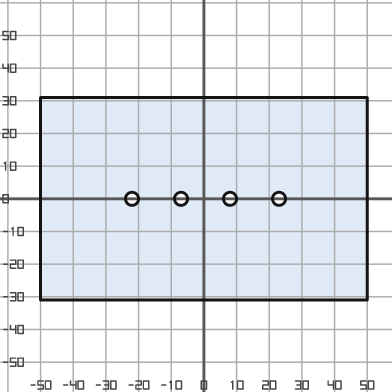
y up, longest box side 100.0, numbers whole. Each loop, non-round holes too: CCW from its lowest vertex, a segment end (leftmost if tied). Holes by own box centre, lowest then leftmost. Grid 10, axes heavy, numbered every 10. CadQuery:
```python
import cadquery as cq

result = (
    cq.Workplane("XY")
    .moveTo(-50.0, -31.0)
    .lineTo(50.0, -31.0)
    .lineTo(50.0, 31.0)
    .lineTo(-50.0, 31.0)
    .close()
    .moveTo(-22.0, 0.0)
    .circle(2.0)
    .moveTo(-7.0, 0.0)
    .circle(2.0)
    .moveTo(8.0, 0.0)
    .circle(2.0)
    .moveTo(23.0, 0.0)
    .circle(2.0)
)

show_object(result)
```